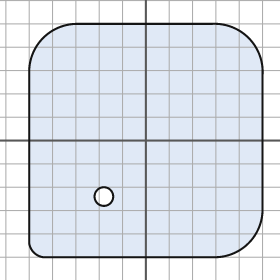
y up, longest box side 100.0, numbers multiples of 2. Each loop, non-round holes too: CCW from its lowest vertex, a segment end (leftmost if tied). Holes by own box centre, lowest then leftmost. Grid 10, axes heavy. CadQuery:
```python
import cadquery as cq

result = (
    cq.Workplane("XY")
    .moveTo(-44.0, -50.0)
    .lineTo(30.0, -50.0)
    .threePointArc((44.0, -44.0), (50.0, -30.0))
    .lineTo(50.0, 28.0)
    .threePointArc((44.0, 44.0), (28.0, 50.0))
    .lineTo(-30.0, 50.0)
    .threePointArc((-44.0, 44.0), (-50.0, 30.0))
    .lineTo(-50.0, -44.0)
    .threePointArc((-48.0, -48.0), (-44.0, -50.0))
    .close()
    .moveTo(-18.0, -24.0)
    .circle(4.0)
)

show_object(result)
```